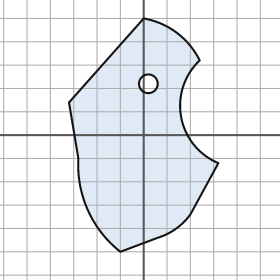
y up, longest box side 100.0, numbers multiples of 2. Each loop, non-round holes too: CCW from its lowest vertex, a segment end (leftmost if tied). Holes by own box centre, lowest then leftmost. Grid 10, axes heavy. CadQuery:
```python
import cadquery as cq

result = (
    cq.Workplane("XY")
    .moveTo(-10.0, -50.0)
    .lineTo(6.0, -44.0)
    .threePointArc((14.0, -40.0), (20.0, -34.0))
    .lineTo(32.0, -12.0)
    .threePointArc((16.0, 8.0), (24.0, 32.0))
    .threePointArc((14.0, 44.0), (0.0, 50.0))
    .lineTo(-32.0, 14.0)
    .lineTo(-28.0, -10.0)
    .threePointArc((-24.0, -32.0), (-10.0, -50.0))
    .close()
    .moveTo(2.0, 22.0)
    .circle(4.0)
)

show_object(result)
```